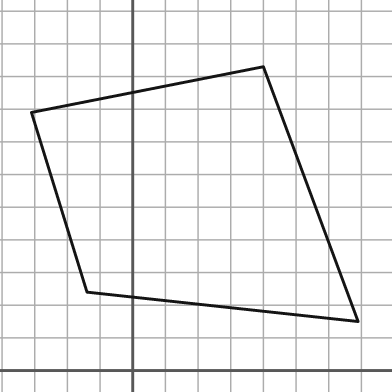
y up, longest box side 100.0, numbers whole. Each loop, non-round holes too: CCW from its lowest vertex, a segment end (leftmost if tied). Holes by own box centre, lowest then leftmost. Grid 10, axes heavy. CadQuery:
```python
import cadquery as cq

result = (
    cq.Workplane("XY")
    .moveTo(69.0, 15.0)
    .lineTo(40.0, 93.0)
    .lineTo(-31.0, 79.0)
    .lineTo(-14.0, 24.0)
    .close()
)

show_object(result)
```